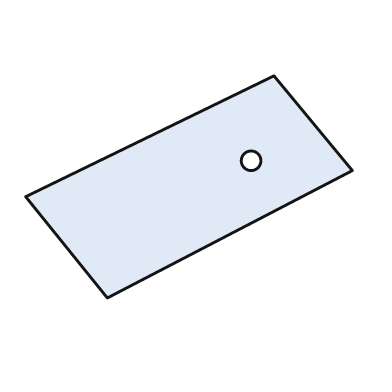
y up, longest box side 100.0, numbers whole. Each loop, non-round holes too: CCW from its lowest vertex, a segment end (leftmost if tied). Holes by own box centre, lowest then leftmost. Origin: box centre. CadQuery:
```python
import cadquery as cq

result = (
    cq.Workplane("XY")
    .moveTo(-25.0, -34.0)
    .lineTo(50.0, 5.0)
    .lineTo(26.0, 34.0)
    .lineTo(-50.0, -3.0)
    .close()
    .moveTo(19.0, 8.0)
    .circle(3.0)
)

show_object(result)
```